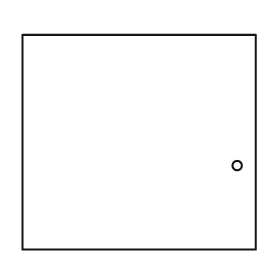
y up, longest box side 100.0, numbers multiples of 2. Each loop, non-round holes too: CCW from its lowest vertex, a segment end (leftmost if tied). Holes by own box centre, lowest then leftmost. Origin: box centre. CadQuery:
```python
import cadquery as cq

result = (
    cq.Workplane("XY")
    .moveTo(-50.0, -46.0)
    .lineTo(50.0, -46.0)
    .lineTo(50.0, 46.0)
    .lineTo(-50.0, 46.0)
    .close()
    .moveTo(42.0, -10.0)
    .circle(2.0)
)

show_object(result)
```